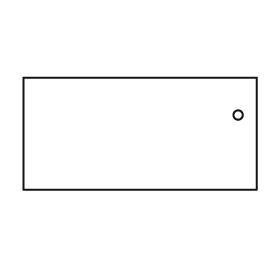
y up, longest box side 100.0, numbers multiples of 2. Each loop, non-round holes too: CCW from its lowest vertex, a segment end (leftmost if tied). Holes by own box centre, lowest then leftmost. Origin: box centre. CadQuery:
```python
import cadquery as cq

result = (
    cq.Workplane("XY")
    .moveTo(-50.0, -24.0)
    .lineTo(50.0, -24.0)
    .lineTo(50.0, 24.0)
    .lineTo(-50.0, 24.0)
    .close()
    .moveTo(42.0, 8.0)
    .circle(2.0)
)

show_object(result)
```